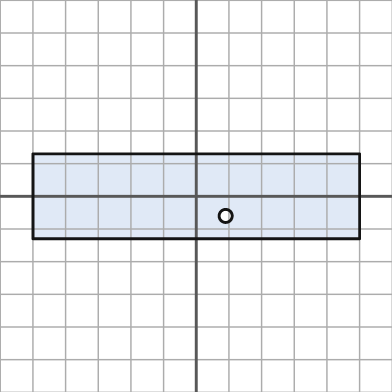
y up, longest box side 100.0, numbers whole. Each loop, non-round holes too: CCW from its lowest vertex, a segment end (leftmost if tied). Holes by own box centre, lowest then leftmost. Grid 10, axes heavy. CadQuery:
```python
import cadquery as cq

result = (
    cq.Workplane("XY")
    .moveTo(-50.0, -13.0)
    .lineTo(50.0, -13.0)
    .lineTo(50.0, 13.0)
    .lineTo(-50.0, 13.0)
    .close()
    .moveTo(9.0, -6.0)
    .circle(2.0)
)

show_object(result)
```